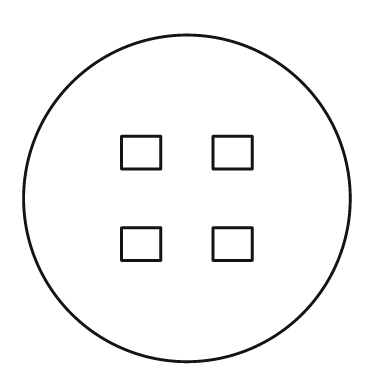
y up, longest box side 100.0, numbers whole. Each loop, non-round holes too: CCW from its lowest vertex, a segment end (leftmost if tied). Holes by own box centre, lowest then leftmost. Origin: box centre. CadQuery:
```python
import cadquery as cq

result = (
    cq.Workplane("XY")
    .moveTo(0.0, 0.0)
    .circle(50.0)
    .moveTo(-20.0, -19.0)
    .lineTo(-8.0, -19.0)
    .lineTo(-8.0, -9.0)
    .lineTo(-20.0, -9.0)
    .close()
    .moveTo(8.0, -19.0)
    .lineTo(20.0, -19.0)
    .lineTo(20.0, -9.0)
    .lineTo(8.0, -9.0)
    .close()
    .moveTo(-20.0, 9.0)
    .lineTo(-8.0, 9.0)
    .lineTo(-8.0, 19.0)
    .lineTo(-20.0, 19.0)
    .close()
    .moveTo(8.0, 9.0)
    .lineTo(20.0, 9.0)
    .lineTo(20.0, 19.0)
    .lineTo(8.0, 19.0)
    .close()
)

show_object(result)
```